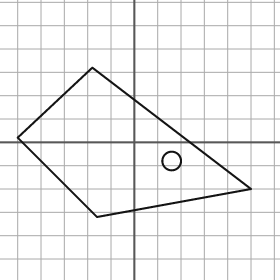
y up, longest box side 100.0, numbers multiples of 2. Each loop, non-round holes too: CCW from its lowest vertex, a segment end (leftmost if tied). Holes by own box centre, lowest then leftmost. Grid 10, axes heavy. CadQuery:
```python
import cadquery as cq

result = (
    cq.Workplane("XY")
    .moveTo(-16.0, -32.0)
    .lineTo(50.0, -20.0)
    .lineTo(-18.0, 32.0)
    .lineTo(-50.0, 2.0)
    .close()
    .moveTo(16.0, -8.0)
    .circle(4.0)
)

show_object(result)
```